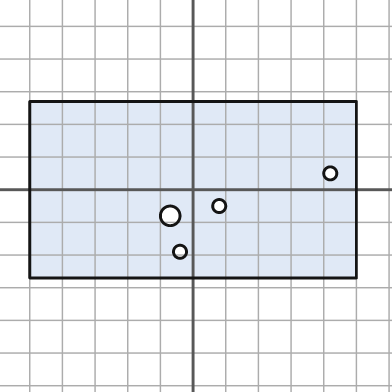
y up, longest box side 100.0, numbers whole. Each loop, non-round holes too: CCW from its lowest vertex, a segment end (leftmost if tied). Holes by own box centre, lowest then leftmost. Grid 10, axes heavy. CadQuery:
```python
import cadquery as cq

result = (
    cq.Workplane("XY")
    .moveTo(-50.0, -27.0)
    .lineTo(50.0, -27.0)
    .lineTo(50.0, 27.0)
    .lineTo(-50.0, 27.0)
    .close()
    .moveTo(-4.0, -19.0)
    .circle(2.0)
    .moveTo(-7.0, -8.0)
    .circle(3.0)
    .moveTo(8.0, -5.0)
    .circle(2.0)
    .moveTo(42.0, 5.0)
    .circle(2.0)
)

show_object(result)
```